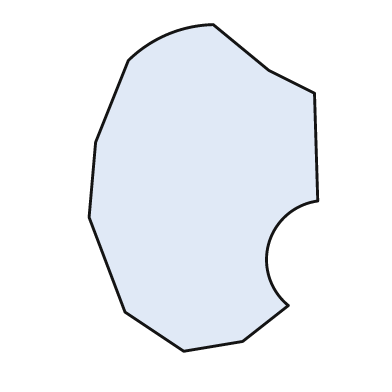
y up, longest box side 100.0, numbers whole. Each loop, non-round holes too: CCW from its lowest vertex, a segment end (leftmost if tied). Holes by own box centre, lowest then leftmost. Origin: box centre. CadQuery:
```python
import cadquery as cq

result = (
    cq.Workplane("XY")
    .moveTo(-6.0, -50.0)
    .lineTo(12.0, -47.0)
    .lineTo(26.0, -36.0)
    .threePointArc((20.0, -17.0), (35.0, -4.0))
    .lineTo(34.0, 29.0)
    .lineTo(20.0, 36.0)
    .lineTo(3.0, 50.0)
    .threePointArc((-11.0, 47.0), (-23.0, 39.0))
    .lineTo(-33.0, 14.0)
    .lineTo(-35.0, -9.0)
    .lineTo(-24.0, -38.0)
    .close()
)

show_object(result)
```